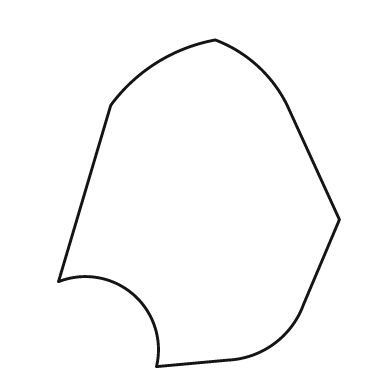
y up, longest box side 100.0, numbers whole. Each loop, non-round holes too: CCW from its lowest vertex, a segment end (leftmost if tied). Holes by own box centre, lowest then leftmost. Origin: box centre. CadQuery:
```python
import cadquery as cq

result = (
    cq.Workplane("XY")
    .moveTo(-13.0, -50.0)
    .lineTo(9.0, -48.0)
    .threePointArc((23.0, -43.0), (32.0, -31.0))
    .lineTo(43.0, -5.0)
    .lineTo(27.0, 30.0)
    .threePointArc((18.0, 42.0), (5.0, 50.0))
    .threePointArc((-13.0, 43.0), (-27.0, 30.0))
    .lineTo(-43.0, -24.0)
    .threePointArc((-20.0, -28.0), (-13.0, -50.0))
    .close()
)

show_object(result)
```